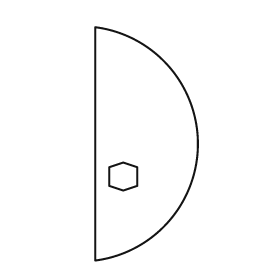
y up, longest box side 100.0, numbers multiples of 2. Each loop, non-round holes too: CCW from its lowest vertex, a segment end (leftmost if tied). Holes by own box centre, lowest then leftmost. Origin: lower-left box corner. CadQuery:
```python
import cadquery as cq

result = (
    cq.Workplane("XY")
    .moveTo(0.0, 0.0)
    .threePointArc((44.0, 50.0), (0.0, 100.0))
    .close()
    .moveTo(12.0, 30.0)
    .lineTo(18.0, 32.0)
    .lineTo(18.0, 40.0)
    .lineTo(12.0, 42.0)
    .lineTo(6.0, 40.0)
    .lineTo(6.0, 32.0)
    .close()
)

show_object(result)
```